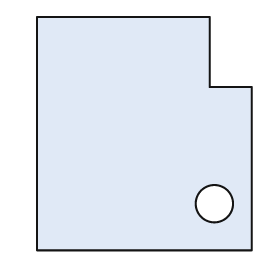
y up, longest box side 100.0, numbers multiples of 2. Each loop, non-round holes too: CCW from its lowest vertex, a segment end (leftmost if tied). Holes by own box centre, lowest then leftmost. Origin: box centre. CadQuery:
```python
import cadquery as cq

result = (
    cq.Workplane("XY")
    .moveTo(-46.0, -50.0)
    .lineTo(46.0, -50.0)
    .lineTo(46.0, 20.0)
    .lineTo(28.0, 20.0)
    .lineTo(28.0, 50.0)
    .lineTo(-46.0, 50.0)
    .close()
    .moveTo(30.0, -30.0)
    .circle(8.0)
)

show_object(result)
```